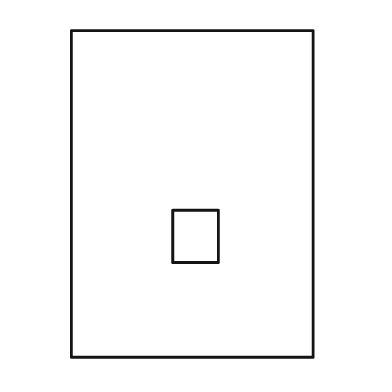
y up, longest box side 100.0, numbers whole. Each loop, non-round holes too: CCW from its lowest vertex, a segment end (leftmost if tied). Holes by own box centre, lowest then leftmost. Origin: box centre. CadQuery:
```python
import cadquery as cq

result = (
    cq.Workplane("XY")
    .moveTo(-37.0, -50.0)
    .lineTo(37.0, -50.0)
    .lineTo(37.0, 50.0)
    .lineTo(-37.0, 50.0)
    .close()
    .moveTo(-6.0, -21.0)
    .lineTo(8.0, -21.0)
    .lineTo(8.0, -5.0)
    .lineTo(-6.0, -5.0)
    .close()
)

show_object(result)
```